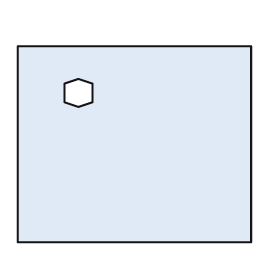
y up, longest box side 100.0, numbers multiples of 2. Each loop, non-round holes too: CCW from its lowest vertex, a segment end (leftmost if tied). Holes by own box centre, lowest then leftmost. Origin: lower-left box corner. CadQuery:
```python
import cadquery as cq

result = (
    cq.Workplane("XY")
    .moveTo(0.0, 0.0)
    .lineTo(100.0, 0.0)
    .lineTo(100.0, 84.0)
    .lineTo(0.0, 84.0)
    .close()
    .moveTo(26.0, 58.0)
    .lineTo(32.0, 60.0)
    .lineTo(32.0, 68.0)
    .lineTo(26.0, 70.0)
    .lineTo(20.0, 68.0)
    .lineTo(20.0, 60.0)
    .close()
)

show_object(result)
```